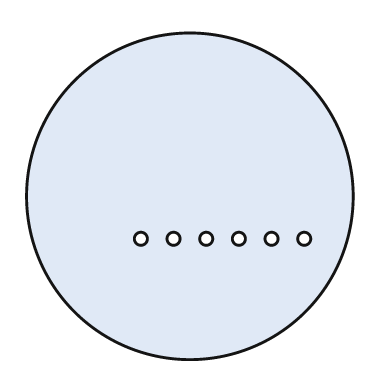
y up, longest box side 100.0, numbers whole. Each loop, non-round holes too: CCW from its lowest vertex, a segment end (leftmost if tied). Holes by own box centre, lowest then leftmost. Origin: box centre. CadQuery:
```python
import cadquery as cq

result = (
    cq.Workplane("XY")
    .moveTo(0.0, 0.0)
    .circle(50.0)
    .moveTo(-15.0, -13.0)
    .circle(2.0)
    .moveTo(-5.0, -13.0)
    .circle(2.0)
    .moveTo(5.0, -13.0)
    .circle(2.0)
    .moveTo(15.0, -13.0)
    .circle(2.0)
    .moveTo(25.0, -13.0)
    .circle(2.0)
    .moveTo(35.0, -13.0)
    .circle(2.0)
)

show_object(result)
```